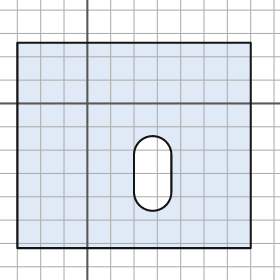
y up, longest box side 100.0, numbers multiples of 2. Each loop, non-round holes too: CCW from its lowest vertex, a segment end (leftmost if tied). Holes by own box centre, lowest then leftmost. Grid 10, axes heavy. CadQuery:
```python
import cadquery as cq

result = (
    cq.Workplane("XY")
    .moveTo(-30.0, -62.0)
    .lineTo(70.0, -62.0)
    .lineTo(70.0, 26.0)
    .lineTo(-30.0, 26.0)
    .close()
    .moveTo(20.0, -38.0)
    .threePointArc((28.0, -46.0), (36.0, -38.0))
    .lineTo(36.0, -22.0)
    .threePointArc((28.0, -14.0), (20.0, -22.0))
    .close()
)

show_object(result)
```